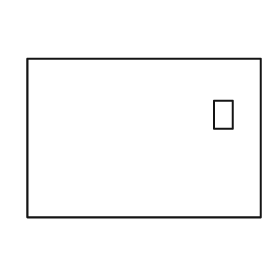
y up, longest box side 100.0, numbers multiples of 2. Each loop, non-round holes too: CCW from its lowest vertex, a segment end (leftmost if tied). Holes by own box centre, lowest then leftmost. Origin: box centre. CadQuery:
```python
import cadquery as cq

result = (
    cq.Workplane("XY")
    .moveTo(-50.0, -34.0)
    .lineTo(50.0, -34.0)
    .lineTo(50.0, 34.0)
    .lineTo(-50.0, 34.0)
    .close()
    .moveTo(30.0, 4.0)
    .lineTo(38.0, 4.0)
    .lineTo(38.0, 16.0)
    .lineTo(30.0, 16.0)
    .close()
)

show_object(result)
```